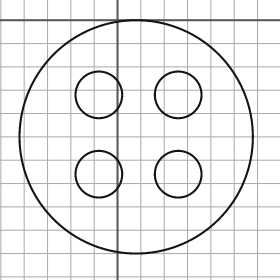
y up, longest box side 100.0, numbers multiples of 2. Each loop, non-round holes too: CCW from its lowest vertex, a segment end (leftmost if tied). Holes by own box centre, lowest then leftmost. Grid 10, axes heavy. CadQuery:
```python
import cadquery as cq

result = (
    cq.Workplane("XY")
    .moveTo(8.0, -50.0)
    .circle(50.0)
    .moveTo(-8.0, -66.0)
    .circle(10.0)
    .moveTo(26.0, -66.0)
    .circle(10.0)
    .moveTo(-8.0, -32.0)
    .circle(10.0)
    .moveTo(26.0, -32.0)
    .circle(10.0)
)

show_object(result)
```